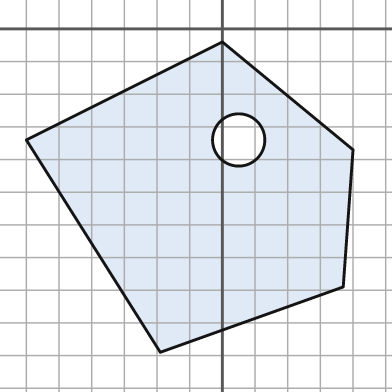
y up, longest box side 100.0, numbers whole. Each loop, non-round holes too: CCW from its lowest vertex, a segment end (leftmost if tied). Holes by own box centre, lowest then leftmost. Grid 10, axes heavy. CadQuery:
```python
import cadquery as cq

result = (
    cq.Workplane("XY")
    .moveTo(-19.0, -99.0)
    .lineTo(37.0, -79.0)
    .lineTo(40.0, -37.0)
    .lineTo(0.0, -4.0)
    .lineTo(-60.0, -34.0)
    .close()
    .moveTo(5.0, -34.0)
    .circle(8.0)
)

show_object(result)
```